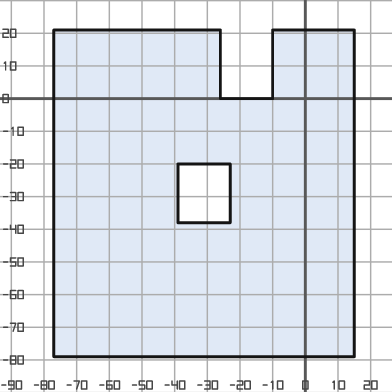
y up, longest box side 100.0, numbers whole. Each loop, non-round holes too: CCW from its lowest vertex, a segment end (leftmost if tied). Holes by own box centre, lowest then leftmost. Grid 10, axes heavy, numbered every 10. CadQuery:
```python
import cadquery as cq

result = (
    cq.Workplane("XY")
    .moveTo(-77.0, -79.0)
    .lineTo(15.0, -79.0)
    .lineTo(15.0, 21.0)
    .lineTo(-10.0, 21.0)
    .lineTo(-10.0, 0.0)
    .lineTo(-26.0, 0.0)
    .lineTo(-26.0, 21.0)
    .lineTo(-77.0, 21.0)
    .close()
    .moveTo(-39.0, -38.0)
    .lineTo(-23.0, -38.0)
    .lineTo(-23.0, -20.0)
    .lineTo(-39.0, -20.0)
    .close()
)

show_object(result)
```